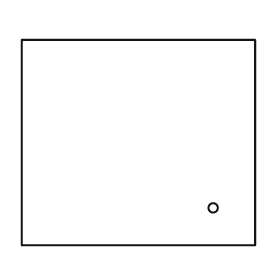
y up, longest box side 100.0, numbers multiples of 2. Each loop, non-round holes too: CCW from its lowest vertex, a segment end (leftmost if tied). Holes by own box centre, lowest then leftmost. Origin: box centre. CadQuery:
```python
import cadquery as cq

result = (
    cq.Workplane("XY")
    .moveTo(-50.0, -44.0)
    .lineTo(50.0, -44.0)
    .lineTo(50.0, 44.0)
    .lineTo(-50.0, 44.0)
    .close()
    .moveTo(32.0, -28.0)
    .circle(2.0)
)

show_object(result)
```